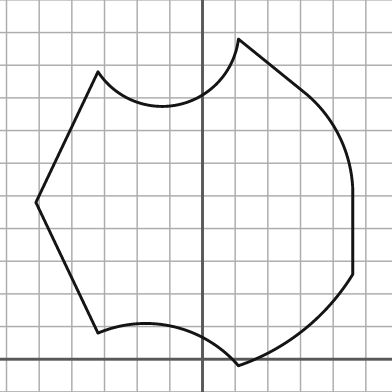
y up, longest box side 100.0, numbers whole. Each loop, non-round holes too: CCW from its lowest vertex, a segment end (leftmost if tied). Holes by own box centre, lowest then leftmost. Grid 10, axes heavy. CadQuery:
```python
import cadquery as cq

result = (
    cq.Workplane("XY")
    .moveTo(11.0, -2.0)
    .threePointArc((31.0, 9.0), (46.0, 26.0))
    .lineTo(46.0, 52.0)
    .threePointArc((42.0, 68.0), (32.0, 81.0))
    .lineTo(11.0, 98.0)
    .threePointArc((-7.0, 78.0), (-32.0, 88.0))
    .lineTo(-51.0, 48.0)
    .lineTo(-32.0, 8.0)
    .threePointArc((-9.0, 10.0), (11.0, -2.0))
    .close()
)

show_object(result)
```